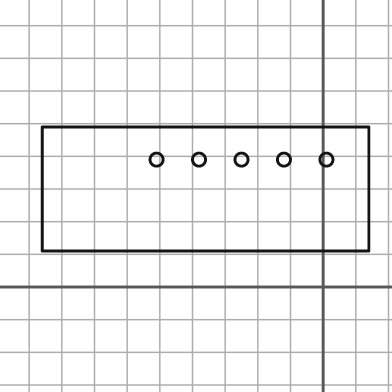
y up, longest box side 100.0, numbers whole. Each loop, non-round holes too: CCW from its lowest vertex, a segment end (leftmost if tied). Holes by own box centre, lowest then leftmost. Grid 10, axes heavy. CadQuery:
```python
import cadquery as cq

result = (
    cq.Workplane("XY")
    .moveTo(-86.0, 11.0)
    .lineTo(14.0, 11.0)
    .lineTo(14.0, 49.0)
    .lineTo(-86.0, 49.0)
    .close()
    .moveTo(-51.0, 39.0)
    .circle(2.0)
    .moveTo(-38.0, 39.0)
    .circle(2.0)
    .moveTo(-25.0, 39.0)
    .circle(2.0)
    .moveTo(-12.0, 39.0)
    .circle(2.0)
    .moveTo(1.0, 39.0)
    .circle(2.0)
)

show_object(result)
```